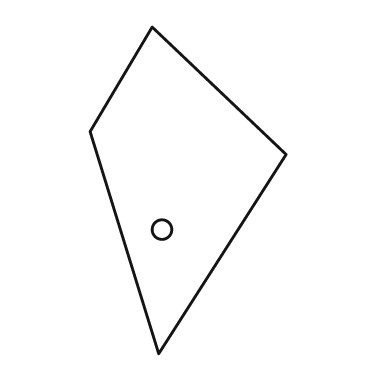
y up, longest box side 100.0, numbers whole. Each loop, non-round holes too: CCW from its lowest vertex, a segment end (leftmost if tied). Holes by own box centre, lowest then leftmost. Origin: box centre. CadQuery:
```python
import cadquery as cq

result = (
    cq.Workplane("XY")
    .moveTo(-9.0, -50.0)
    .lineTo(30.0, 11.0)
    .lineTo(-11.0, 50.0)
    .lineTo(-30.0, 18.0)
    .close()
    .moveTo(-8.0, -12.0)
    .circle(3.0)
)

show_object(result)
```